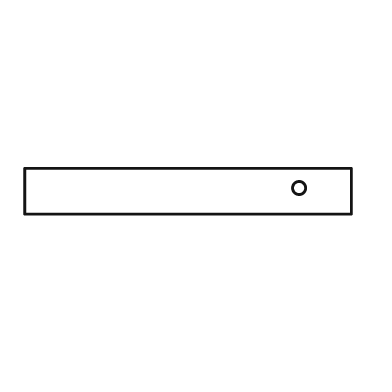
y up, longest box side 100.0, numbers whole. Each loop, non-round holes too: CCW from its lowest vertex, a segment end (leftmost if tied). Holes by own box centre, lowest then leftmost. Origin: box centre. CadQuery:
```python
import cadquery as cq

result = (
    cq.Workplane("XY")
    .moveTo(-50.0, -7.0)
    .lineTo(50.0, -7.0)
    .lineTo(50.0, 7.0)
    .lineTo(-50.0, 7.0)
    .close()
    .moveTo(34.0, 1.0)
    .circle(2.0)
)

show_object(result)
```